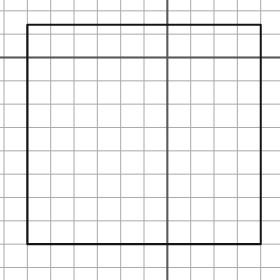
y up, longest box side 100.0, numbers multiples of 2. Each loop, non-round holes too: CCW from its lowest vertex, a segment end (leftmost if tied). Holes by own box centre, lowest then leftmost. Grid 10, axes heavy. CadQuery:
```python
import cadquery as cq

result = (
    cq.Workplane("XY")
    .moveTo(-60.0, -80.0)
    .lineTo(40.0, -80.0)
    .lineTo(40.0, 14.0)
    .lineTo(-60.0, 14.0)
    .close()
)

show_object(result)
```